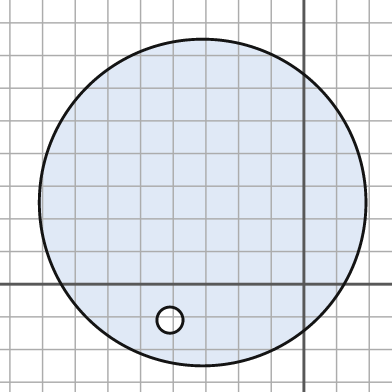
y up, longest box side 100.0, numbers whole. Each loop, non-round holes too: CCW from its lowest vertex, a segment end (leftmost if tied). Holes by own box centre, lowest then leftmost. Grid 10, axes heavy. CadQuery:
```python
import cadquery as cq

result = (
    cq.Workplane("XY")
    .moveTo(-31.0, 25.0)
    .circle(50.0)
    .moveTo(-41.0, -11.0)
    .circle(4.0)
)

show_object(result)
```